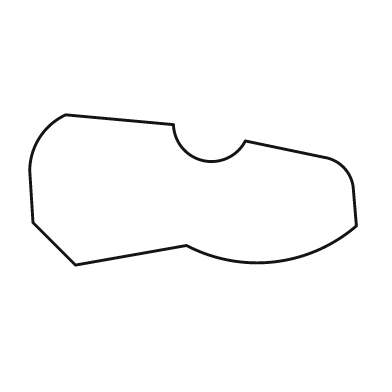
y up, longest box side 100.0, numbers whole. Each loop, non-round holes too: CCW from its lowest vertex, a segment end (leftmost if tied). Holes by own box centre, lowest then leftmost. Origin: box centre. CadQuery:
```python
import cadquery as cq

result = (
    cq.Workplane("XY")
    .moveTo(-36.0, -23.0)
    .lineTo(-2.0, -17.0)
    .threePointArc((25.0, -22.0), (50.0, -11.0))
    .lineTo(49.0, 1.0)
    .threePointArc((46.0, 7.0), (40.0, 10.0))
    .lineTo(16.0, 15.0)
    .threePointArc((3.0, 9.0), (-6.0, 20.0))
    .lineTo(-39.0, 23.0)
    .threePointArc((-47.0, 16.0), (-50.0, 6.0))
    .lineTo(-49.0, -10.0)
    .close()
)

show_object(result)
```